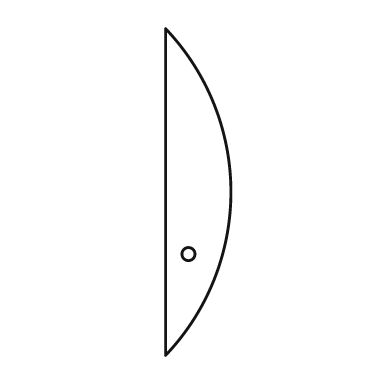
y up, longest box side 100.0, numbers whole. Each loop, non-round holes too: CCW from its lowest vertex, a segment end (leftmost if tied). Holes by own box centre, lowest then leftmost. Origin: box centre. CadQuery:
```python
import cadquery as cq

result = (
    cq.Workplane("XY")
    .moveTo(-10.0, -50.0)
    .threePointArc((10.0, 0.0), (-10.0, 50.0))
    .close()
    .moveTo(-3.0, -19.0)
    .circle(2.0)
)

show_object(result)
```